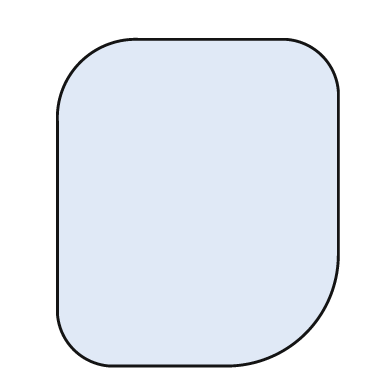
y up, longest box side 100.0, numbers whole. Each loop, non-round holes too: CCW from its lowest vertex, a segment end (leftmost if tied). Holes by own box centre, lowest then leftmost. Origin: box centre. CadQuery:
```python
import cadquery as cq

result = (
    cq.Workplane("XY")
    .moveTo(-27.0, -50.0)
    .lineTo(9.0, -50.0)
    .threePointArc((33.0, -40.0), (43.0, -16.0))
    .lineTo(43.0, 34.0)
    .threePointArc((38.0, 45.0), (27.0, 50.0))
    .lineTo(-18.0, 50.0)
    .threePointArc((-36.0, 43.0), (-43.0, 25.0))
    .lineTo(-43.0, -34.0)
    .threePointArc((-38.0, -45.0), (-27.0, -50.0))
    .close()
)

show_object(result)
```